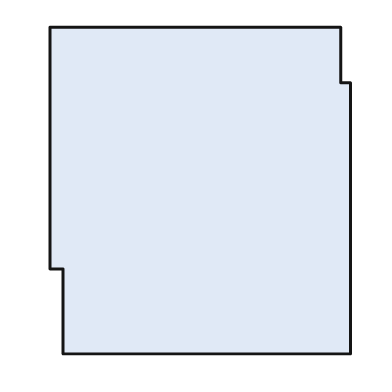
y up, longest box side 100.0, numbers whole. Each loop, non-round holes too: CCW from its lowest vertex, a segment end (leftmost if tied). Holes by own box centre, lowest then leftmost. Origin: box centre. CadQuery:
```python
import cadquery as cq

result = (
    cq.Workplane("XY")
    .moveTo(-42.0, -50.0)
    .lineTo(46.0, -50.0)
    .lineTo(46.0, 33.0)
    .lineTo(43.0, 33.0)
    .lineTo(43.0, 50.0)
    .lineTo(-46.0, 50.0)
    .lineTo(-46.0, -24.0)
    .lineTo(-42.0, -24.0)
    .close()
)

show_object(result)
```